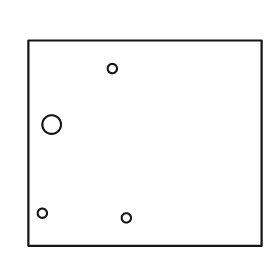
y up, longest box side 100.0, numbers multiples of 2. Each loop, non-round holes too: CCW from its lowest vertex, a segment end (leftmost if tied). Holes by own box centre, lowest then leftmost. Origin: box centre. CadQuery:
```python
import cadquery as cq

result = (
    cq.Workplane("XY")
    .moveTo(-50.0, -44.0)
    .lineTo(50.0, -44.0)
    .lineTo(50.0, 44.0)
    .lineTo(-50.0, 44.0)
    .close()
    .moveTo(-8.0, -32.0)
    .circle(2.0)
    .moveTo(-44.0, -30.0)
    .circle(2.0)
    .moveTo(-40.0, 8.0)
    .circle(4.0)
    .moveTo(-14.0, 32.0)
    .circle(2.0)
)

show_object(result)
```